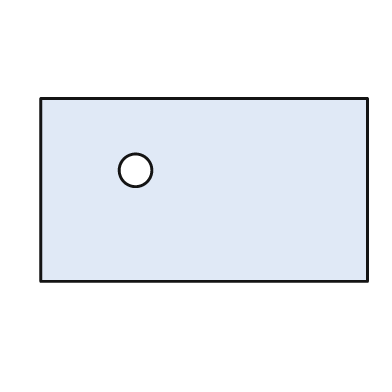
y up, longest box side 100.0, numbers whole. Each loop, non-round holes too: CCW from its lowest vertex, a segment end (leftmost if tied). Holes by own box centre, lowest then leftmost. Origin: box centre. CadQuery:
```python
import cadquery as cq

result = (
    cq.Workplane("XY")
    .moveTo(-50.0, -28.0)
    .lineTo(50.0, -28.0)
    .lineTo(50.0, 28.0)
    .lineTo(-50.0, 28.0)
    .close()
    .moveTo(-21.0, 6.0)
    .circle(5.0)
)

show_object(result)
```